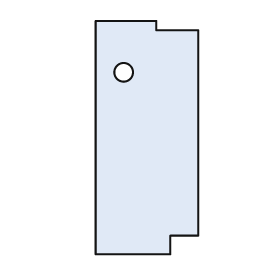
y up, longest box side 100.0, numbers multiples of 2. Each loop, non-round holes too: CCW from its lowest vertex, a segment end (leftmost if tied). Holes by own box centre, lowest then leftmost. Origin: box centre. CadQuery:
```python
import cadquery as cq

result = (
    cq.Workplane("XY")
    .moveTo(-22.0, -50.0)
    .lineTo(10.0, -50.0)
    .lineTo(10.0, -42.0)
    .lineTo(22.0, -42.0)
    .lineTo(22.0, 46.0)
    .lineTo(4.0, 46.0)
    .lineTo(4.0, 50.0)
    .lineTo(-22.0, 50.0)
    .close()
    .moveTo(-10.0, 28.0)
    .circle(4.0)
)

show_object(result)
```